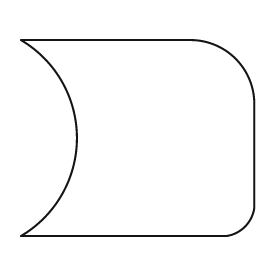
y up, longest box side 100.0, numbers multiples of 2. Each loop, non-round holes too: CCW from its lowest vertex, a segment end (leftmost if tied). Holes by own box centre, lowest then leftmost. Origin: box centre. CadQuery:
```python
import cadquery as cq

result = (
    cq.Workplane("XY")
    .moveTo(-50.0, -42.0)
    .lineTo(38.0, -42.0)
    .threePointArc((46.0, -38.0), (50.0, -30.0))
    .lineTo(50.0, 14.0)
    .threePointArc((42.0, 34.0), (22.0, 42.0))
    .lineTo(-50.0, 42.0)
    .threePointArc((-26.0, 0.0), (-50.0, -42.0))
    .close()
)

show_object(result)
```